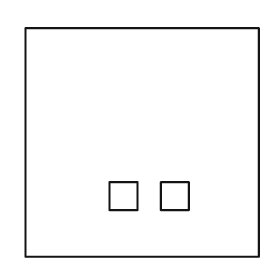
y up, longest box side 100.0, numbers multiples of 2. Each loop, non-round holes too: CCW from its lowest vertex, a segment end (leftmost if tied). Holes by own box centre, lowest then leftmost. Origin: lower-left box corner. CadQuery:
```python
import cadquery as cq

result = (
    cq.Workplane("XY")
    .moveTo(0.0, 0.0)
    .lineTo(100.0, 0.0)
    .lineTo(100.0, 98.0)
    .lineTo(0.0, 98.0)
    .close()
    .moveTo(36.0, 20.0)
    .lineTo(48.0, 20.0)
    .lineTo(48.0, 32.0)
    .lineTo(36.0, 32.0)
    .close()
    .moveTo(58.0, 20.0)
    .lineTo(70.0, 20.0)
    .lineTo(70.0, 32.0)
    .lineTo(58.0, 32.0)
    .close()
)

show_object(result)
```